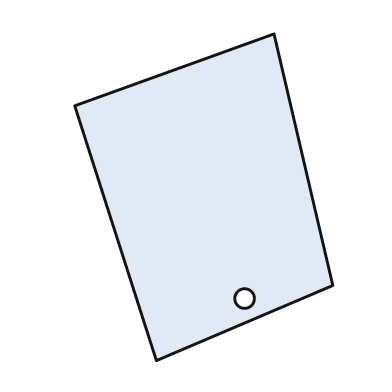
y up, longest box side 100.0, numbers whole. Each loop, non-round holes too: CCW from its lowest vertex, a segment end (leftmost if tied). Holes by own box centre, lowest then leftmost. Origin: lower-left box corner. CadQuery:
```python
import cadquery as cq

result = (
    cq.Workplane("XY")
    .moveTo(25.0, 0.0)
    .lineTo(79.0, 23.0)
    .lineTo(61.0, 100.0)
    .lineTo(0.0, 78.0)
    .close()
    .moveTo(52.0, 19.0)
    .circle(3.0)
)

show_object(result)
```